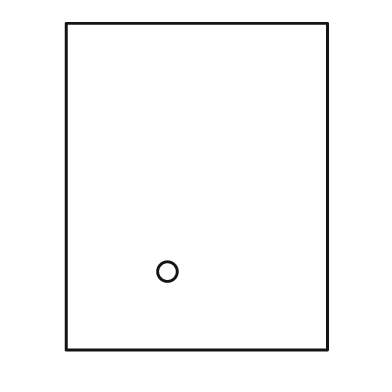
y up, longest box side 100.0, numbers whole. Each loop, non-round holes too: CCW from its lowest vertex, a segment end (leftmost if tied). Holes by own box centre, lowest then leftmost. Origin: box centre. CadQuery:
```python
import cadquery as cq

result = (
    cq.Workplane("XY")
    .moveTo(-40.0, -50.0)
    .lineTo(40.0, -50.0)
    .lineTo(40.0, 50.0)
    .lineTo(-40.0, 50.0)
    .close()
    .moveTo(-9.0, -26.0)
    .circle(3.0)
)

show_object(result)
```